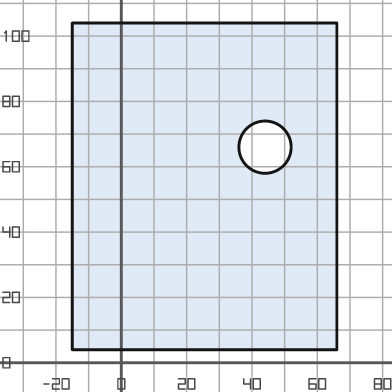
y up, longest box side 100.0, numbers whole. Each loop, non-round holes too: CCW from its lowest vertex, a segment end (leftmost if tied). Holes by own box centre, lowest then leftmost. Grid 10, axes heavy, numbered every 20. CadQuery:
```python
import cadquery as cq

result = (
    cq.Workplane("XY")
    .moveTo(-15.0, 4.0)
    .lineTo(66.0, 4.0)
    .lineTo(66.0, 104.0)
    .lineTo(-15.0, 104.0)
    .close()
    .moveTo(44.0, 66.0)
    .circle(8.0)
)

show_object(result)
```